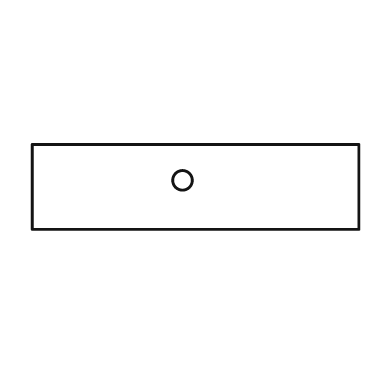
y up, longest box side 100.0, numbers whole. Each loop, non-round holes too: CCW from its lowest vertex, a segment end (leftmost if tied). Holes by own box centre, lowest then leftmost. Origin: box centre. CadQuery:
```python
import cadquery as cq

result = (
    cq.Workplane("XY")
    .moveTo(-50.0, -13.0)
    .lineTo(50.0, -13.0)
    .lineTo(50.0, 13.0)
    .lineTo(-50.0, 13.0)
    .close()
    .moveTo(-4.0, 2.0)
    .circle(3.0)
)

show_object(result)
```